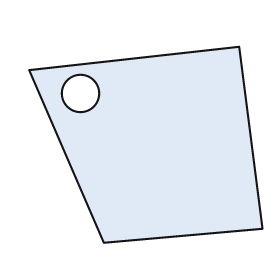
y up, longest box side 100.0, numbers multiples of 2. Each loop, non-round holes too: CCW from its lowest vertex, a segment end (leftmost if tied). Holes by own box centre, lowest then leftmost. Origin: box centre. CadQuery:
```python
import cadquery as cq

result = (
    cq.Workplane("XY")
    .moveTo(-18.0, -42.0)
    .lineTo(50.0, -36.0)
    .lineTo(40.0, 42.0)
    .lineTo(-50.0, 32.0)
    .close()
    .moveTo(-28.0, 22.0)
    .circle(8.0)
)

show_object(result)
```